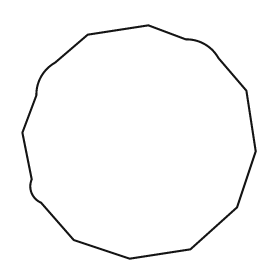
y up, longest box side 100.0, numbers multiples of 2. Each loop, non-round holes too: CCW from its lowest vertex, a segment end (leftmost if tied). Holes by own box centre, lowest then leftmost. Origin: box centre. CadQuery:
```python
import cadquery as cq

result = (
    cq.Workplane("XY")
    .moveTo(-4.0, -50.0)
    .lineTo(22.0, -46.0)
    .lineTo(42.0, -28.0)
    .lineTo(50.0, -4.0)
    .lineTo(46.0, 22.0)
    .lineTo(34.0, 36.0)
    .threePointArc((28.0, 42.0), (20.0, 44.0))
    .lineTo(4.0, 50.0)
    .lineTo(-22.0, 46.0)
    .lineTo(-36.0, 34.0)
    .threePointArc((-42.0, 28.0), (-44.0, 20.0))
    .lineTo(-50.0, 4.0)
    .lineTo(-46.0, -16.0)
    .threePointArc((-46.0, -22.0), (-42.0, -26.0))
    .lineTo(-28.0, -42.0)
    .close()
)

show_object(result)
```